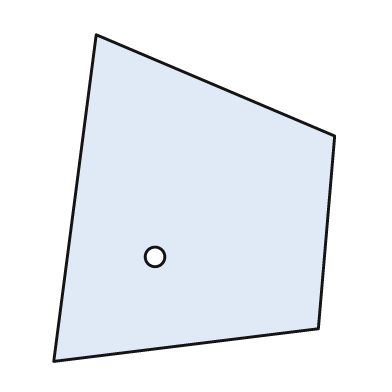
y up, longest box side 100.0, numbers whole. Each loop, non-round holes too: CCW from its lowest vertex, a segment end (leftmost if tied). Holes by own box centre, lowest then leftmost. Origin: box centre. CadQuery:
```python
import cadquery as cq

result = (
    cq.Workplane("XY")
    .moveTo(-43.0, -50.0)
    .lineTo(38.0, -40.0)
    .lineTo(43.0, 19.0)
    .lineTo(-30.0, 50.0)
    .close()
    .moveTo(-12.0, -18.0)
    .circle(3.0)
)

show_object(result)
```